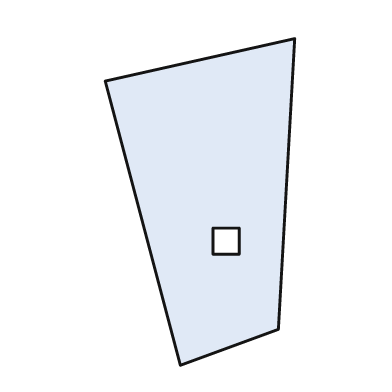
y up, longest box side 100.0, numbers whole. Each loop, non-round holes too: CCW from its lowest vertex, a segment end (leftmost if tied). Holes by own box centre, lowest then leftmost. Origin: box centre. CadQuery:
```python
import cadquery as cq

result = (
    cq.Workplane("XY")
    .moveTo(-6.0, -50.0)
    .lineTo(24.0, -39.0)
    .lineTo(29.0, 50.0)
    .lineTo(-29.0, 37.0)
    .close()
    .moveTo(4.0, -16.0)
    .lineTo(12.0, -16.0)
    .lineTo(12.0, -8.0)
    .lineTo(4.0, -8.0)
    .close()
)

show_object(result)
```